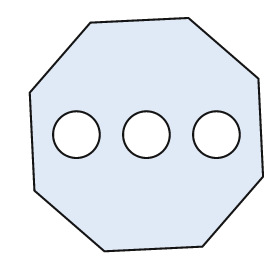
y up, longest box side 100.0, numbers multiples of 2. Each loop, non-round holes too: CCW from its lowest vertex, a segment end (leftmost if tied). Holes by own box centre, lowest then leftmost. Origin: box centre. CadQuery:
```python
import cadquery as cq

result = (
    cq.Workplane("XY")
    .moveTo(-18.0, -50.0)
    .lineTo(24.0, -48.0)
    .lineTo(50.0, -18.0)
    .lineTo(48.0, 24.0)
    .lineTo(18.0, 50.0)
    .lineTo(-24.0, 48.0)
    .lineTo(-50.0, 18.0)
    .lineTo(-48.0, -24.0)
    .close()
    .moveTo(-30.0, 0.0)
    .circle(10.0)
    .moveTo(0.0, 0.0)
    .circle(10.0)
    .moveTo(30.0, 0.0)
    .circle(10.0)
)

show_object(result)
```